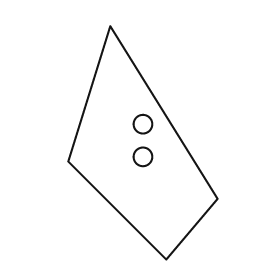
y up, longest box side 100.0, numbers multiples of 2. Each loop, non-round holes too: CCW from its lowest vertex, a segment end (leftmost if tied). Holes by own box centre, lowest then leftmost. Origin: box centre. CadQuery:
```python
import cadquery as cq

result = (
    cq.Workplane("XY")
    .moveTo(10.0, -50.0)
    .lineTo(32.0, -24.0)
    .lineTo(-14.0, 50.0)
    .lineTo(-32.0, -8.0)
    .close()
    .moveTo(0.0, -6.0)
    .circle(4.0)
    .moveTo(0.0, 8.0)
    .circle(4.0)
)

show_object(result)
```